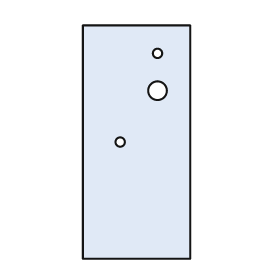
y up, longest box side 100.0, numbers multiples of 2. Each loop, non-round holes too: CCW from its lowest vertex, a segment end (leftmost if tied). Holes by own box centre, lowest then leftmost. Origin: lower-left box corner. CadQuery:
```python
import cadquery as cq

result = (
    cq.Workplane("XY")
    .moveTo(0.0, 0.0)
    .lineTo(46.0, 0.0)
    .lineTo(46.0, 100.0)
    .lineTo(0.0, 100.0)
    .close()
    .moveTo(16.0, 50.0)
    .circle(2.0)
    .moveTo(32.0, 72.0)
    .circle(4.0)
    .moveTo(32.0, 88.0)
    .circle(2.0)
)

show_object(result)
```